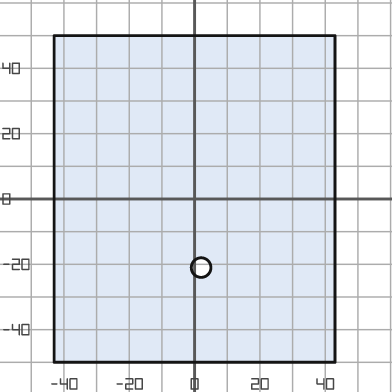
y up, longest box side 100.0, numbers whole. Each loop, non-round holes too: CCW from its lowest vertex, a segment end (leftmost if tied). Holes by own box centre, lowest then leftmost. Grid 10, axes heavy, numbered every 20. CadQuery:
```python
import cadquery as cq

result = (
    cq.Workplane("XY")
    .moveTo(-43.0, -50.0)
    .lineTo(43.0, -50.0)
    .lineTo(43.0, 50.0)
    .lineTo(-43.0, 50.0)
    .close()
    .moveTo(2.0, -21.0)
    .circle(3.0)
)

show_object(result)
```